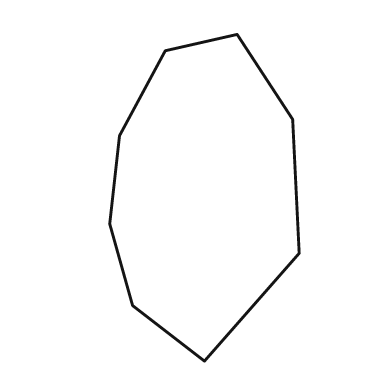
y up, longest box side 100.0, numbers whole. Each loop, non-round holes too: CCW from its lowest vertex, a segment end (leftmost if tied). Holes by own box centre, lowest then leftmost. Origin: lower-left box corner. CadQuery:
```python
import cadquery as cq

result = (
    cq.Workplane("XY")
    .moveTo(29.0, 0.0)
    .lineTo(58.0, 33.0)
    .lineTo(56.0, 74.0)
    .lineTo(39.0, 100.0)
    .lineTo(17.0, 95.0)
    .lineTo(3.0, 69.0)
    .lineTo(0.0, 42.0)
    .lineTo(7.0, 17.0)
    .close()
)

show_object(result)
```